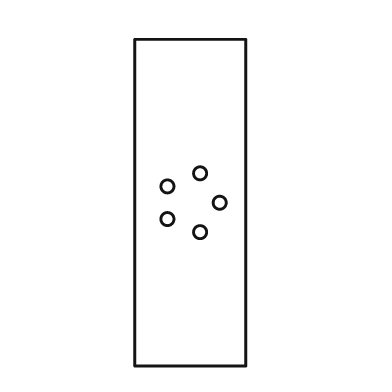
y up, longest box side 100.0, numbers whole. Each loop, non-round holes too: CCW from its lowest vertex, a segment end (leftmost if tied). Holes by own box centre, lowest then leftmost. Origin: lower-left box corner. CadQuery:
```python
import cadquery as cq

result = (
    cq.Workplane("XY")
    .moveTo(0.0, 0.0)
    .lineTo(34.0, 0.0)
    .lineTo(34.0, 100.0)
    .lineTo(0.0, 100.0)
    .close()
    .moveTo(20.0, 41.0)
    .circle(2.0)
    .moveTo(10.0, 45.0)
    .circle(2.0)
    .moveTo(26.0, 50.0)
    .circle(2.0)
    .moveTo(10.0, 55.0)
    .circle(2.0)
    .moveTo(20.0, 59.0)
    .circle(2.0)
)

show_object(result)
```